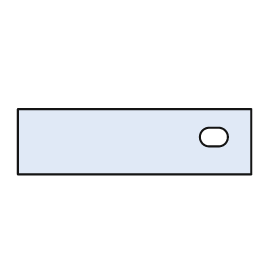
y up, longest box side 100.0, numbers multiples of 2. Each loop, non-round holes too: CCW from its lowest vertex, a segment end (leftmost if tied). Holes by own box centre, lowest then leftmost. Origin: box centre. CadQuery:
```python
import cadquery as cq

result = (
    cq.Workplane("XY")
    .moveTo(-50.0, -14.0)
    .lineTo(50.0, -14.0)
    .lineTo(50.0, 14.0)
    .lineTo(-50.0, 14.0)
    .close()
    .moveTo(32.0, -2.0)
    .lineTo(36.0, -2.0)
    .threePointArc((40.0, 2.0), (36.0, 6.0))
    .lineTo(32.0, 6.0)
    .threePointArc((28.0, 2.0), (32.0, -2.0))
    .close()
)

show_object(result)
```